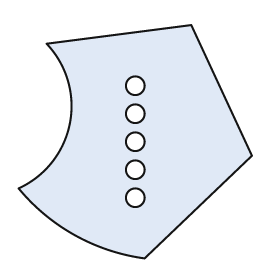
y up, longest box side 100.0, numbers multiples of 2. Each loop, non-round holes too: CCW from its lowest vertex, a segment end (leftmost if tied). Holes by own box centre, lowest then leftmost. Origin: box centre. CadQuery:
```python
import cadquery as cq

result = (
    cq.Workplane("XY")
    .moveTo(4.0, -50.0)
    .lineTo(50.0, -6.0)
    .lineTo(24.0, 50.0)
    .lineTo(-38.0, 42.0)
    .threePointArc((-28.0, 8.0), (-50.0, -20.0))
    .threePointArc((-26.0, -40.0), (4.0, -50.0))
    .close()
    .moveTo(0.0, -24.0)
    .circle(4.0)
    .moveTo(0.0, -12.0)
    .circle(4.0)
    .moveTo(0.0, 0.0)
    .circle(4.0)
    .moveTo(0.0, 12.0)
    .circle(4.0)
    .moveTo(0.0, 24.0)
    .circle(4.0)
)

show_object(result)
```